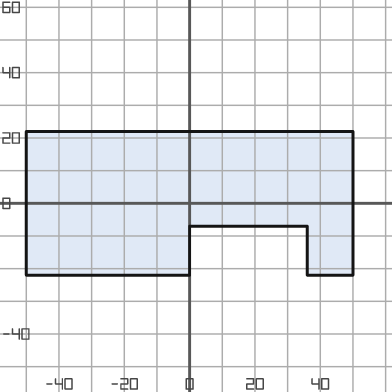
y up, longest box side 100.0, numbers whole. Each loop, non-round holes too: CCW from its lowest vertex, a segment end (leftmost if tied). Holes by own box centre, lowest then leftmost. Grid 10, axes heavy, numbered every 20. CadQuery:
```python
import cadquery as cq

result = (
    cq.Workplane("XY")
    .moveTo(-50.0, -22.0)
    .lineTo(0.0, -22.0)
    .lineTo(0.0, -7.0)
    .lineTo(36.0, -7.0)
    .lineTo(36.0, -22.0)
    .lineTo(50.0, -22.0)
    .lineTo(50.0, 22.0)
    .lineTo(-50.0, 22.0)
    .close()
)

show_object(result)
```